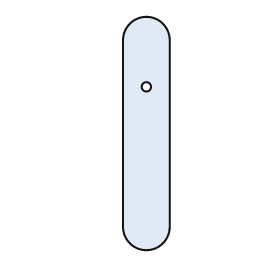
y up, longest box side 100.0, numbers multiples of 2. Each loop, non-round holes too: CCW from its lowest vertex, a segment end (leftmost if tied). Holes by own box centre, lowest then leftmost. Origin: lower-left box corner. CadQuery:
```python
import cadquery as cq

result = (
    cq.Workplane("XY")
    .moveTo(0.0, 10.0)
    .threePointArc((10.0, 0.0), (20.0, 10.0))
    .lineTo(20.0, 90.0)
    .threePointArc((10.0, 100.0), (0.0, 90.0))
    .close()
    .moveTo(10.0, 70.0)
    .circle(2.0)
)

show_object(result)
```